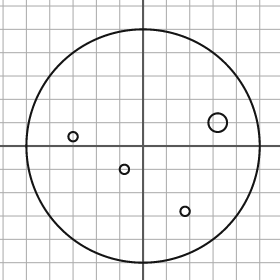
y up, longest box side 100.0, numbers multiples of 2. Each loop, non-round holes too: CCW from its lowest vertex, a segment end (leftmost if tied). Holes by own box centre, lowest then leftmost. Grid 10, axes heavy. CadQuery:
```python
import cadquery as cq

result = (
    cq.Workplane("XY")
    .moveTo(0.0, 0.0)
    .circle(50.0)
    .moveTo(18.0, -28.0)
    .circle(2.0)
    .moveTo(-8.0, -10.0)
    .circle(2.0)
    .moveTo(-30.0, 4.0)
    .circle(2.0)
    .moveTo(32.0, 10.0)
    .circle(4.0)
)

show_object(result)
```